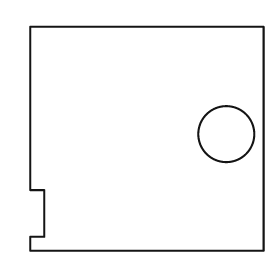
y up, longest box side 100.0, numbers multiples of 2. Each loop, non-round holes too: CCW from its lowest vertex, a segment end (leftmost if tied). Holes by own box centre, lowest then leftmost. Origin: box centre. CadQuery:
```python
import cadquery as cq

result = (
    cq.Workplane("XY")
    .moveTo(-50.0, -48.0)
    .lineTo(50.0, -48.0)
    .lineTo(50.0, 48.0)
    .lineTo(-50.0, 48.0)
    .lineTo(-50.0, -22.0)
    .lineTo(-44.0, -22.0)
    .lineTo(-44.0, -42.0)
    .lineTo(-50.0, -42.0)
    .close()
    .moveTo(34.0, 2.0)
    .circle(12.0)
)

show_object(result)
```